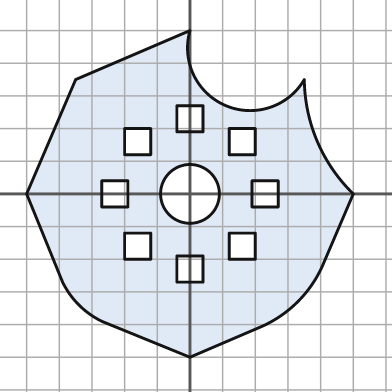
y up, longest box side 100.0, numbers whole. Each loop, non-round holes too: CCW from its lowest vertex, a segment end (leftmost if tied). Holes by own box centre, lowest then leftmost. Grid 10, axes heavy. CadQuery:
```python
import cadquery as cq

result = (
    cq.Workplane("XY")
    .moveTo(0.0, -50.0)
    .lineTo(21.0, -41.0)
    .threePointArc((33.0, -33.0), (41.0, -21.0))
    .lineTo(50.0, 0.0)
    .threePointArc((39.0, 16.0), (35.0, 35.0))
    .threePointArc((11.0, 27.0), (0.0, 50.0))
    .lineTo(-35.0, 35.0)
    .lineTo(-50.0, 0.0)
    .lineTo(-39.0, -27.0)
    .threePointArc((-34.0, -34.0), (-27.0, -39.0))
    .close()
    .moveTo(-4.0, -27.0)
    .lineTo(4.0, -27.0)
    .lineTo(4.0, -19.0)
    .lineTo(-4.0, -19.0)
    .close()
    .moveTo(-20.0, -20.0)
    .lineTo(-12.0, -20.0)
    .lineTo(-12.0, -12.0)
    .lineTo(-20.0, -12.0)
    .close()
    .moveTo(12.0, -20.0)
    .lineTo(20.0, -20.0)
    .lineTo(20.0, -12.0)
    .lineTo(12.0, -12.0)
    .close()
    .moveTo(-27.0, -4.0)
    .lineTo(-19.0, -4.0)
    .lineTo(-19.0, 4.0)
    .lineTo(-27.0, 4.0)
    .close()
    .moveTo(0.0, 0.0)
    .circle(9.0)
    .moveTo(19.0, -4.0)
    .lineTo(27.0, -4.0)
    .lineTo(27.0, 4.0)
    .lineTo(19.0, 4.0)
    .close()
    .moveTo(-20.0, 12.0)
    .lineTo(-12.0, 12.0)
    .lineTo(-12.0, 20.0)
    .lineTo(-20.0, 20.0)
    .close()
    .moveTo(12.0, 12.0)
    .lineTo(20.0, 12.0)
    .lineTo(20.0, 20.0)
    .lineTo(12.0, 20.0)
    .close()
    .moveTo(-4.0, 19.0)
    .lineTo(4.0, 19.0)
    .lineTo(4.0, 27.0)
    .lineTo(-4.0, 27.0)
    .close()
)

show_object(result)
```